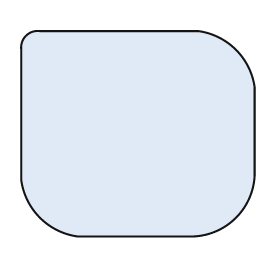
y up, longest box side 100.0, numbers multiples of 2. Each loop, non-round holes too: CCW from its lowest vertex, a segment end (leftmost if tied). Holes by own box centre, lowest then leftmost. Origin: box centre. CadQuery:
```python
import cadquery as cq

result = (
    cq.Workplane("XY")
    .moveTo(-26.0, -44.0)
    .lineTo(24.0, -44.0)
    .threePointArc((42.0, -36.0), (50.0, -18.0))
    .lineTo(50.0, 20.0)
    .threePointArc((42.0, 36.0), (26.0, 44.0))
    .lineTo(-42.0, 44.0)
    .threePointArc((-48.0, 42.0), (-50.0, 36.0))
    .lineTo(-50.0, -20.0)
    .threePointArc((-42.0, -36.0), (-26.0, -44.0))
    .close()
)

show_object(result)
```